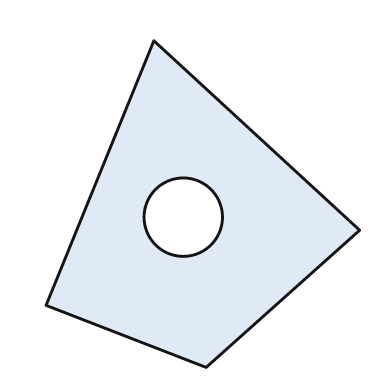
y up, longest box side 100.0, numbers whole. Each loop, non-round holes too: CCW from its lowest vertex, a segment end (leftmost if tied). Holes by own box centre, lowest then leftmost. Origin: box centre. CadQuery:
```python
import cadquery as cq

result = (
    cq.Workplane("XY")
    .moveTo(1.0, -50.0)
    .lineTo(48.0, -8.0)
    .lineTo(-15.0, 50.0)
    .lineTo(-48.0, -31.0)
    .close()
    .moveTo(-6.0, -4.0)
    .circle(12.0)
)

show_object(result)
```